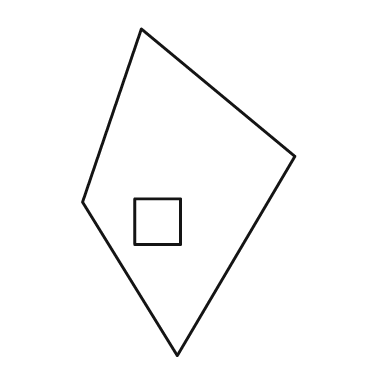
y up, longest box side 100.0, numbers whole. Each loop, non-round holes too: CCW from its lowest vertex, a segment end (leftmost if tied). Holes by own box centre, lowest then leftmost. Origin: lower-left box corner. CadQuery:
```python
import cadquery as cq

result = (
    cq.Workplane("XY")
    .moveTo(29.0, 0.0)
    .lineTo(65.0, 61.0)
    .lineTo(18.0, 100.0)
    .lineTo(0.0, 47.0)
    .close()
    .moveTo(16.0, 34.0)
    .lineTo(30.0, 34.0)
    .lineTo(30.0, 48.0)
    .lineTo(16.0, 48.0)
    .close()
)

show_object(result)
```